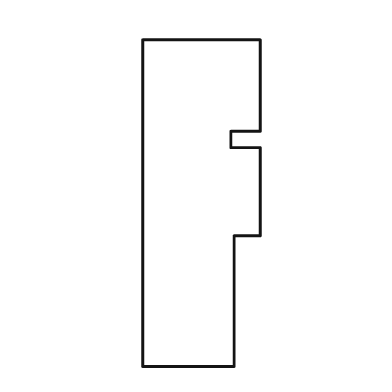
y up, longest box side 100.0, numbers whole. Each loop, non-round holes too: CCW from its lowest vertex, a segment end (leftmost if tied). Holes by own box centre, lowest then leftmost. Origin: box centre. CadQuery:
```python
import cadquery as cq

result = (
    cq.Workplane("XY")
    .moveTo(-18.0, -50.0)
    .lineTo(10.0, -50.0)
    .lineTo(10.0, -10.0)
    .lineTo(18.0, -10.0)
    .lineTo(18.0, 17.0)
    .lineTo(9.0, 17.0)
    .lineTo(9.0, 22.0)
    .lineTo(18.0, 22.0)
    .lineTo(18.0, 50.0)
    .lineTo(-18.0, 50.0)
    .close()
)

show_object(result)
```